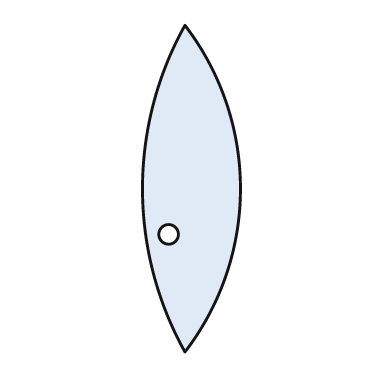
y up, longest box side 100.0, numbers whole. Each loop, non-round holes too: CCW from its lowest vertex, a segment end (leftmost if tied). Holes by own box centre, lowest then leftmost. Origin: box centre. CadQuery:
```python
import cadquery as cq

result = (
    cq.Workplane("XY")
    .moveTo(-2.0, -50.0)
    .threePointArc((15.0, 0.0), (-2.0, 50.0))
    .threePointArc((-15.0, 0.0), (-2.0, -50.0))
    .close()
    .moveTo(-7.0, -14.0)
    .circle(3.0)
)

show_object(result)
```